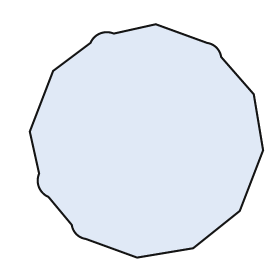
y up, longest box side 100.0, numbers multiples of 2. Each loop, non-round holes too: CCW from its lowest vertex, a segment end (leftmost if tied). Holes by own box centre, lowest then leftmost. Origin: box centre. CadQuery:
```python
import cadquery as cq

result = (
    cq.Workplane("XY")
    .moveTo(-4.0, -50.0)
    .lineTo(20.0, -46.0)
    .lineTo(40.0, -30.0)
    .lineTo(50.0, -4.0)
    .lineTo(46.0, 20.0)
    .lineTo(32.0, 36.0)
    .threePointArc((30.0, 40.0), (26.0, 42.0))
    .lineTo(4.0, 50.0)
    .lineTo(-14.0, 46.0)
    .threePointArc((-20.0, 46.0), (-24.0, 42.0))
    .lineTo(-40.0, 30.0)
    .lineTo(-50.0, 4.0)
    .lineTo(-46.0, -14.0)
    .threePointArc((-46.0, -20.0), (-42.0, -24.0))
    .lineTo(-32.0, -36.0)
    .threePointArc((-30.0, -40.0), (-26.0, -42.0))
    .close()
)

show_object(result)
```